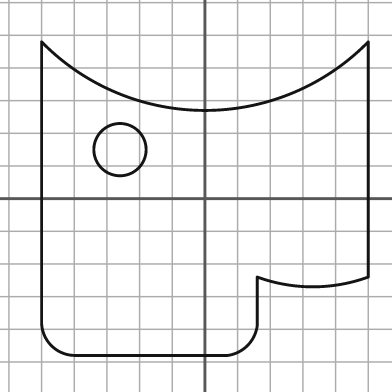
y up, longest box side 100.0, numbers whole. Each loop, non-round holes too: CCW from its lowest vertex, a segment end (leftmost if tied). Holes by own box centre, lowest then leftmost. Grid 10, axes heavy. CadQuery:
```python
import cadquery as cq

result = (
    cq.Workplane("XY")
    .moveTo(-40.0, -48.0)
    .lineTo(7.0, -48.0)
    .threePointArc((13.0, -45.0), (16.0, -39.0))
    .lineTo(16.0, -24.0)
    .threePointArc((33.0, -27.0), (50.0, -24.0))
    .lineTo(50.0, 48.0)
    .threePointArc((0.0, 27.0), (-50.0, 48.0))
    .lineTo(-50.0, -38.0)
    .threePointArc((-47.0, -45.0), (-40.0, -48.0))
    .close()
    .moveTo(-26.0, 15.0)
    .circle(8.0)
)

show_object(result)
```